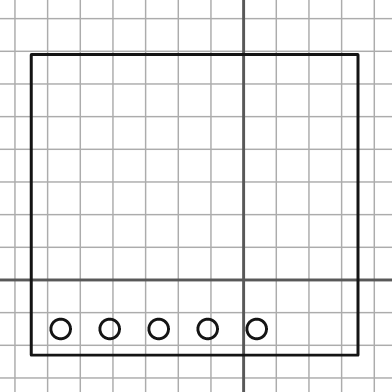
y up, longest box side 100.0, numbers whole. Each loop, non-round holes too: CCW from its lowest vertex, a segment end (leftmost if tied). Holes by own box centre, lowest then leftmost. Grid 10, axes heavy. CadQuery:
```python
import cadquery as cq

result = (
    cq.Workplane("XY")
    .moveTo(-65.0, -23.0)
    .lineTo(35.0, -23.0)
    .lineTo(35.0, 69.0)
    .lineTo(-65.0, 69.0)
    .close()
    .moveTo(-56.0, -15.0)
    .circle(3.0)
    .moveTo(-41.0, -15.0)
    .circle(3.0)
    .moveTo(-26.0, -15.0)
    .circle(3.0)
    .moveTo(-11.0, -15.0)
    .circle(3.0)
    .moveTo(4.0, -15.0)
    .circle(3.0)
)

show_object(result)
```